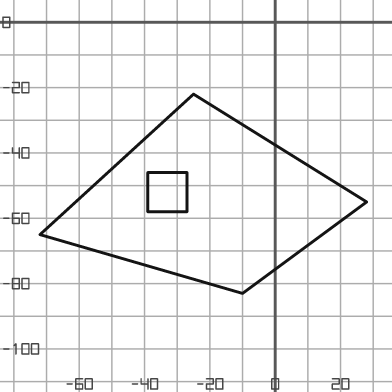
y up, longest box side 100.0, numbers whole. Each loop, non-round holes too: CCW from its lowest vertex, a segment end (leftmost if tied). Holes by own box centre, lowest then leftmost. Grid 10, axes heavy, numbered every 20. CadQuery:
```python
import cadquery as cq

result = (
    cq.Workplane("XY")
    .moveTo(-10.0, -83.0)
    .lineTo(28.0, -55.0)
    .lineTo(-25.0, -22.0)
    .lineTo(-72.0, -65.0)
    .close()
    .moveTo(-39.0, -58.0)
    .lineTo(-27.0, -58.0)
    .lineTo(-27.0, -46.0)
    .lineTo(-39.0, -46.0)
    .close()
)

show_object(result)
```